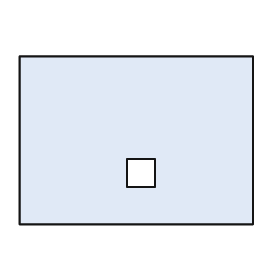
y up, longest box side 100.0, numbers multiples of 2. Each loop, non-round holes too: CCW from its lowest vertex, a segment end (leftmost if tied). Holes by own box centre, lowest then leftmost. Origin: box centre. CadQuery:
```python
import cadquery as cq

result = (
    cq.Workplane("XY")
    .moveTo(-50.0, -36.0)
    .lineTo(50.0, -36.0)
    .lineTo(50.0, 36.0)
    .lineTo(-50.0, 36.0)
    .close()
    .moveTo(-4.0, -20.0)
    .lineTo(8.0, -20.0)
    .lineTo(8.0, -8.0)
    .lineTo(-4.0, -8.0)
    .close()
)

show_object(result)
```